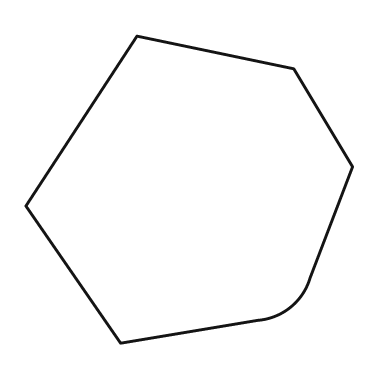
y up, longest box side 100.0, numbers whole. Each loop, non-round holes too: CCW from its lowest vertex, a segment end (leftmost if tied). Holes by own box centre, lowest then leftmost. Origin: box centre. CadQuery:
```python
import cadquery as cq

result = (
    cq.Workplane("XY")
    .moveTo(-21.0, -47.0)
    .lineTo(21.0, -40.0)
    .threePointArc((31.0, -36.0), (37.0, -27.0))
    .lineTo(50.0, 7.0)
    .lineTo(32.0, 37.0)
    .lineTo(-16.0, 47.0)
    .lineTo(-50.0, -5.0)
    .close()
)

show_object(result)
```